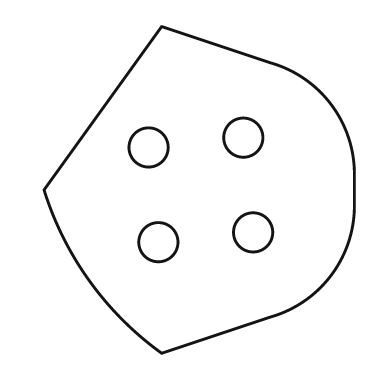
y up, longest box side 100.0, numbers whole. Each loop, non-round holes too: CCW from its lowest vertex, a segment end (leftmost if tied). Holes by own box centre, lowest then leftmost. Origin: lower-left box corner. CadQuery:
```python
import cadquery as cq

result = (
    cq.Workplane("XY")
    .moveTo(36.0, 0.0)
    .lineTo(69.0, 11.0)
    .threePointArc((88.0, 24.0), (95.0, 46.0))
    .lineTo(95.0, 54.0)
    .threePointArc((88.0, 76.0), (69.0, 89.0))
    .lineTo(36.0, 100.0)
    .lineTo(0.0, 50.0)
    .threePointArc((14.0, 22.0), (36.0, 0.0))
    .close()
    .moveTo(35.0, 34.0)
    .circle(6.0)
    .moveTo(64.0, 37.0)
    .circle(6.0)
    .moveTo(32.0, 63.0)
    .circle(6.0)
    .moveTo(61.0, 66.0)
    .circle(6.0)
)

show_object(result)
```